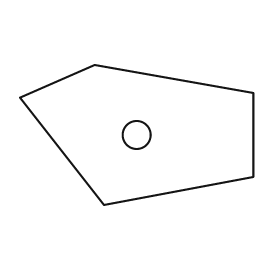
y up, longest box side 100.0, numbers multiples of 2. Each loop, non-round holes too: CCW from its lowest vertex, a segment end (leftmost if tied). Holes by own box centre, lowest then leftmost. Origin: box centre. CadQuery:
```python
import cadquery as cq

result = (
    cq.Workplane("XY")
    .moveTo(-14.0, -30.0)
    .lineTo(50.0, -18.0)
    .lineTo(50.0, 18.0)
    .lineTo(-18.0, 30.0)
    .lineTo(-50.0, 16.0)
    .close()
    .moveTo(0.0, 0.0)
    .circle(6.0)
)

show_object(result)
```